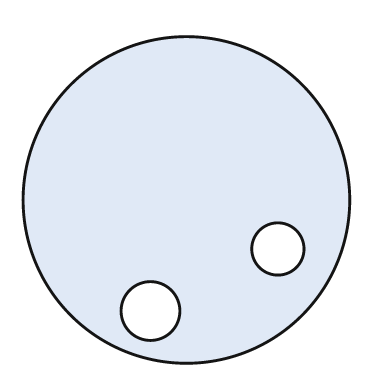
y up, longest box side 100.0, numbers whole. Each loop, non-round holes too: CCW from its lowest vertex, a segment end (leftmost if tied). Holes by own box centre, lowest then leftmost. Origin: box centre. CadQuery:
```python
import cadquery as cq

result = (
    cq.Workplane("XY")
    .moveTo(0.0, 0.0)
    .circle(50.0)
    .moveTo(-11.0, -34.0)
    .circle(9.0)
    .moveTo(28.0, -15.0)
    .circle(8.0)
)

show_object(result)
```